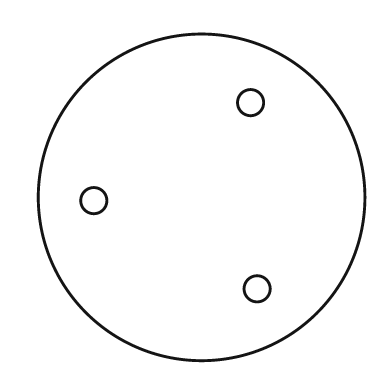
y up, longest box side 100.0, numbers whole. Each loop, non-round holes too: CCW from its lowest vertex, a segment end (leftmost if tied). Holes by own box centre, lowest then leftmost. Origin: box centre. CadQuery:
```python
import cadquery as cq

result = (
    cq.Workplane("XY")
    .moveTo(0.0, 0.0)
    .circle(50.0)
    .moveTo(17.0, -28.0)
    .circle(4.0)
    .moveTo(-33.0, -1.0)
    .circle(4.0)
    .moveTo(15.0, 29.0)
    .circle(4.0)
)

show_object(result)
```